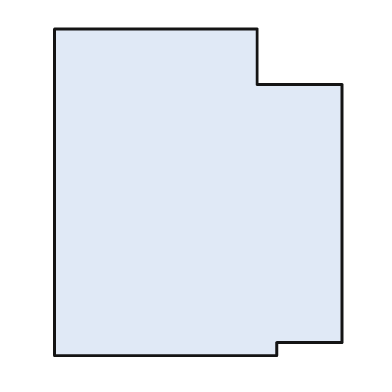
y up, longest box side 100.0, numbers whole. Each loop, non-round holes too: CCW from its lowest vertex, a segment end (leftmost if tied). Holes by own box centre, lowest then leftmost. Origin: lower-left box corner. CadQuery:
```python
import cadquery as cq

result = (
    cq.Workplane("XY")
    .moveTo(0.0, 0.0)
    .lineTo(68.0, 0.0)
    .lineTo(68.0, 4.0)
    .lineTo(88.0, 4.0)
    .lineTo(88.0, 83.0)
    .lineTo(62.0, 83.0)
    .lineTo(62.0, 100.0)
    .lineTo(0.0, 100.0)
    .close()
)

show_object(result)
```